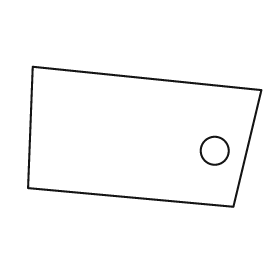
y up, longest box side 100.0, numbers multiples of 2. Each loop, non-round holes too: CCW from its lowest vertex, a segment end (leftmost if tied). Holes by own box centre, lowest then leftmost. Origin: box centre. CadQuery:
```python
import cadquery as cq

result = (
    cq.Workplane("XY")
    .moveTo(38.0, -30.0)
    .lineTo(50.0, 20.0)
    .lineTo(-48.0, 30.0)
    .lineTo(-50.0, -22.0)
    .close()
    .moveTo(30.0, -6.0)
    .circle(6.0)
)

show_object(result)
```